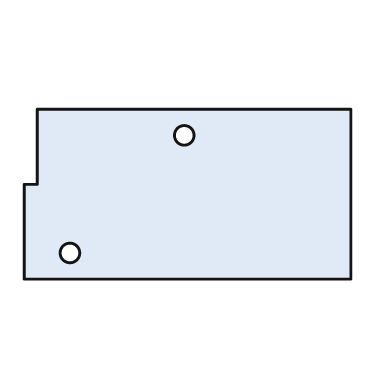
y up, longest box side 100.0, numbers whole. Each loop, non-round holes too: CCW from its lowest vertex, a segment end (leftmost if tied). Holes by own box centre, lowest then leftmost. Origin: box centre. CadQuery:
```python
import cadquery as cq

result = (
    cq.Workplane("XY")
    .moveTo(-50.0, -26.0)
    .lineTo(50.0, -26.0)
    .lineTo(50.0, 26.0)
    .lineTo(-46.0, 26.0)
    .lineTo(-46.0, 3.0)
    .lineTo(-50.0, 3.0)
    .close()
    .moveTo(-36.0, -18.0)
    .circle(3.0)
    .moveTo(-1.0, 18.0)
    .circle(3.0)
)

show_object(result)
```